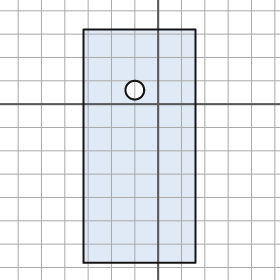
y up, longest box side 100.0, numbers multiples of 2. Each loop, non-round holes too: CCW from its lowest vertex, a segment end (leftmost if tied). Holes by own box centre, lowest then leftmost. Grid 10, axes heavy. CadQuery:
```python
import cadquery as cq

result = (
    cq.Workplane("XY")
    .moveTo(-32.0, -68.0)
    .lineTo(16.0, -68.0)
    .lineTo(16.0, 32.0)
    .lineTo(-32.0, 32.0)
    .close()
    .moveTo(-10.0, 6.0)
    .circle(4.0)
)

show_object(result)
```